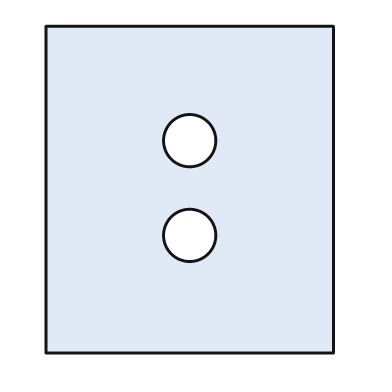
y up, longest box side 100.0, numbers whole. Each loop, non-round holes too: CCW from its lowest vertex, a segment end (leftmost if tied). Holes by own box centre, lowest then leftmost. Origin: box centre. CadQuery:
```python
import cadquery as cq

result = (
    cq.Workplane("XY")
    .moveTo(-44.0, -50.0)
    .lineTo(44.0, -50.0)
    .lineTo(44.0, 50.0)
    .lineTo(-44.0, 50.0)
    .close()
    .moveTo(0.0, -14.0)
    .circle(8.0)
    .moveTo(0.0, 15.0)
    .circle(8.0)
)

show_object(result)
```